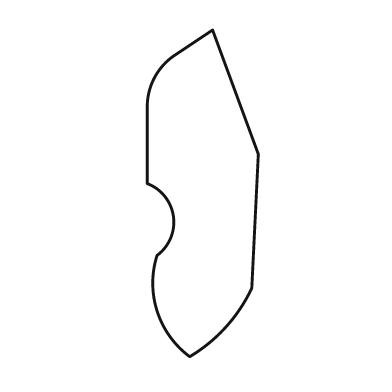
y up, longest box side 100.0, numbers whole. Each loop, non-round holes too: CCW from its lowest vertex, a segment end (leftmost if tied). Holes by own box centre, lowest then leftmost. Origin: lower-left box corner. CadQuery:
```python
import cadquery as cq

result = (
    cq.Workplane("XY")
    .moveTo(13.0, 0.0)
    .threePointArc((24.0, 9.0), (32.0, 21.0))
    .lineTo(34.0, 62.0)
    .lineTo(20.0, 100.0)
    .lineTo(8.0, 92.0)
    .threePointArc((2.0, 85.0), (0.0, 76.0))
    .lineTo(0.0, 53.0)
    .threePointArc((8.0, 43.0), (3.0, 31.0))
    .threePointArc((3.0, 14.0), (13.0, 0.0))
    .close()
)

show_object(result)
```